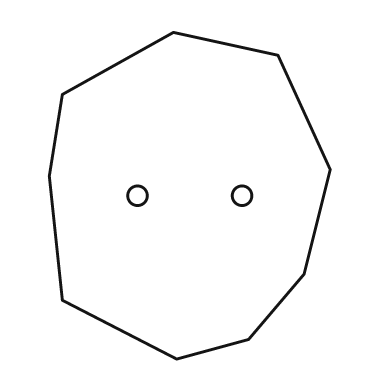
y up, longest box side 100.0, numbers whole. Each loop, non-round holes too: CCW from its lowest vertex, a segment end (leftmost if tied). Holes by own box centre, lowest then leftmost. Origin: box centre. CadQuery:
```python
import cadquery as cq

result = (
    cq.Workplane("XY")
    .moveTo(-4.0, -50.0)
    .lineTo(18.0, -44.0)
    .lineTo(35.0, -24.0)
    .lineTo(43.0, 8.0)
    .lineTo(27.0, 43.0)
    .lineTo(-5.0, 50.0)
    .lineTo(-39.0, 31.0)
    .lineTo(-43.0, 6.0)
    .lineTo(-39.0, -32.0)
    .close()
    .moveTo(-16.0, 0.0)
    .circle(3.0)
    .moveTo(16.0, 0.0)
    .circle(3.0)
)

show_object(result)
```